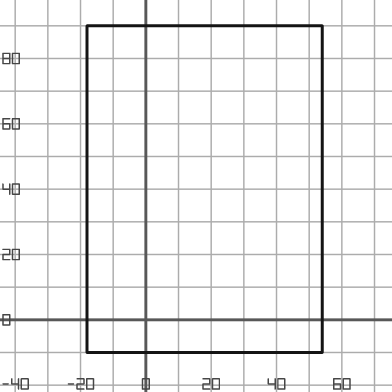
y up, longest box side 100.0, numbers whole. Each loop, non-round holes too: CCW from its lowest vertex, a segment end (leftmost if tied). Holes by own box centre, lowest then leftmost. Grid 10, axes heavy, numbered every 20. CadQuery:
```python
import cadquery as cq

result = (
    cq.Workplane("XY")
    .moveTo(-18.0, -10.0)
    .lineTo(54.0, -10.0)
    .lineTo(54.0, 90.0)
    .lineTo(-18.0, 90.0)
    .close()
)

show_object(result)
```